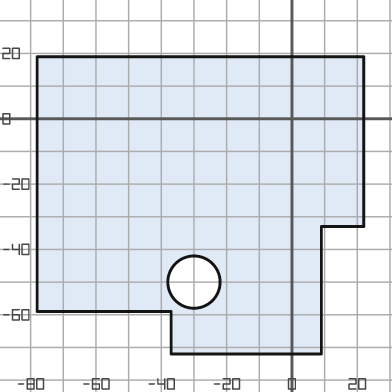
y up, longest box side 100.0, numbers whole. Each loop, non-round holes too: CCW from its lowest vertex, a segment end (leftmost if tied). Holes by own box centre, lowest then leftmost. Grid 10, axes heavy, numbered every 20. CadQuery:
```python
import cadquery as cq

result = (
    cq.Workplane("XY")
    .moveTo(-37.0, -72.0)
    .lineTo(9.0, -72.0)
    .lineTo(9.0, -33.0)
    .lineTo(22.0, -33.0)
    .lineTo(22.0, 19.0)
    .lineTo(-78.0, 19.0)
    .lineTo(-78.0, -59.0)
    .lineTo(-37.0, -59.0)
    .close()
    .moveTo(-30.0, -50.0)
    .circle(8.0)
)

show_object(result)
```